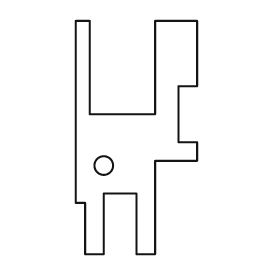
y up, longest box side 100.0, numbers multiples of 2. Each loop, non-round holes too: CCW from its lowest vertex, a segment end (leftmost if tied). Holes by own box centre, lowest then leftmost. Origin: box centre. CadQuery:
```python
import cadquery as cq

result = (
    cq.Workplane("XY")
    .moveTo(-22.0, -50.0)
    .lineTo(-14.0, -50.0)
    .lineTo(-14.0, -24.0)
    .lineTo(0.0, -24.0)
    .lineTo(0.0, -50.0)
    .lineTo(8.0, -50.0)
    .lineTo(8.0, -10.0)
    .lineTo(26.0, -10.0)
    .lineTo(26.0, -2.0)
    .lineTo(18.0, -2.0)
    .lineTo(18.0, 22.0)
    .lineTo(26.0, 22.0)
    .lineTo(26.0, 50.0)
    .lineTo(8.0, 50.0)
    .lineTo(8.0, 10.0)
    .lineTo(-20.0, 10.0)
    .lineTo(-20.0, 50.0)
    .lineTo(-26.0, 50.0)
    .lineTo(-26.0, -28.0)
    .lineTo(-22.0, -28.0)
    .close()
    .moveTo(-14.0, -12.0)
    .circle(4.0)
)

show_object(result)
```